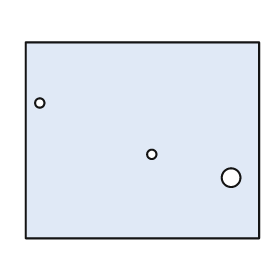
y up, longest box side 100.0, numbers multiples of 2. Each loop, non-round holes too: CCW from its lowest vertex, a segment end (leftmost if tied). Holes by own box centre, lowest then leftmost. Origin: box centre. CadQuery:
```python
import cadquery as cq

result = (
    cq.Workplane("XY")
    .moveTo(-50.0, -42.0)
    .lineTo(50.0, -42.0)
    .lineTo(50.0, 42.0)
    .lineTo(-50.0, 42.0)
    .close()
    .moveTo(38.0, -16.0)
    .circle(4.0)
    .moveTo(4.0, -6.0)
    .circle(2.0)
    .moveTo(-44.0, 16.0)
    .circle(2.0)
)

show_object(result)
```